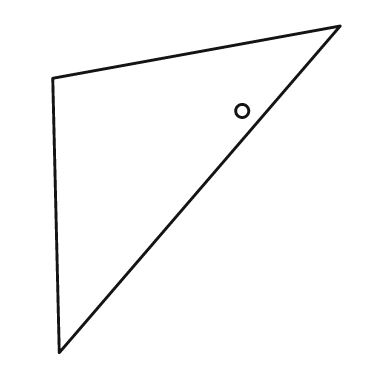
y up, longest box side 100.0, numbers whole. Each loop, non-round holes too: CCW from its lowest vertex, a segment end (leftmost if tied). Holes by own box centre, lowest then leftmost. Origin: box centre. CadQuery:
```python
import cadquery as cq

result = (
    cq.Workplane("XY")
    .moveTo(-42.0, -50.0)
    .lineTo(44.0, 50.0)
    .lineTo(-44.0, 34.0)
    .close()
    .moveTo(14.0, 24.0)
    .circle(2.0)
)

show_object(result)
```